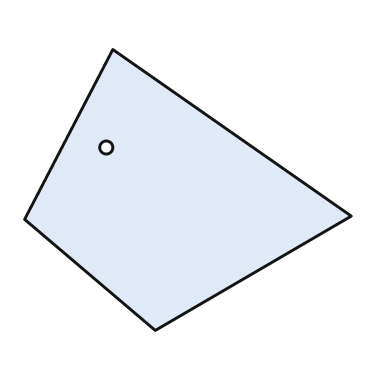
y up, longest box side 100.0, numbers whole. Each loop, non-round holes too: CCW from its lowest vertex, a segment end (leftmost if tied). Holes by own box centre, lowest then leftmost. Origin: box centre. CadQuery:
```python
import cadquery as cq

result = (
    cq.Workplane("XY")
    .moveTo(-10.0, -43.0)
    .lineTo(50.0, -8.0)
    .lineTo(-23.0, 43.0)
    .lineTo(-50.0, -9.0)
    .close()
    .moveTo(-25.0, 13.0)
    .circle(2.0)
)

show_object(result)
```